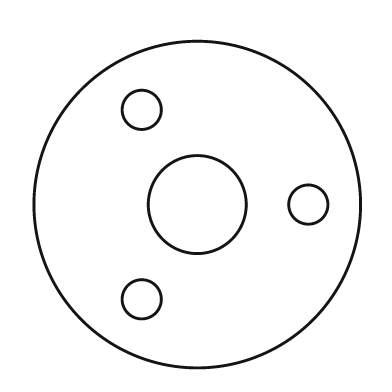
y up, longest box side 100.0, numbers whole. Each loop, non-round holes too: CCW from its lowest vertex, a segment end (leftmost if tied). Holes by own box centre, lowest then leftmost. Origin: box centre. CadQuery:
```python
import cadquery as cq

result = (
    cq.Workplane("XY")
    .moveTo(0.0, 0.0)
    .circle(50.0)
    .moveTo(-17.0, -29.0)
    .circle(6.0)
    .moveTo(0.0, 0.0)
    .circle(15.0)
    .moveTo(34.0, 0.0)
    .circle(6.0)
    .moveTo(-17.0, 29.0)
    .circle(6.0)
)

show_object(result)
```